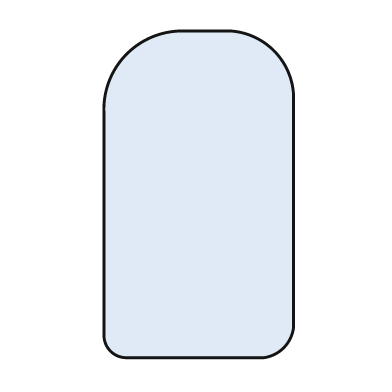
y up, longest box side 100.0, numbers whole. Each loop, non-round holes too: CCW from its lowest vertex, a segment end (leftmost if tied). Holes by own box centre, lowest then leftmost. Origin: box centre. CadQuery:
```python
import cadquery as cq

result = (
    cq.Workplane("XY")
    .moveTo(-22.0, -50.0)
    .lineTo(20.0, -50.0)
    .threePointArc((26.0, -47.0), (29.0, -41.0))
    .lineTo(29.0, 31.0)
    .threePointArc((23.0, 44.0), (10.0, 50.0))
    .lineTo(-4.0, 50.0)
    .threePointArc((-22.0, 43.0), (-29.0, 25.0))
    .lineTo(-29.0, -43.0)
    .threePointArc((-27.0, -48.0), (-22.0, -50.0))
    .close()
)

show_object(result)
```